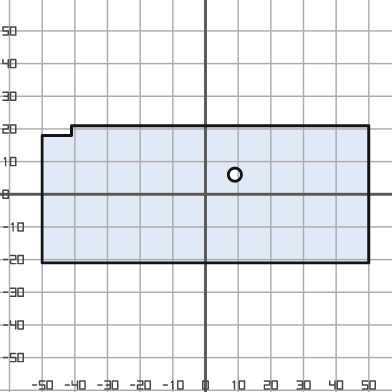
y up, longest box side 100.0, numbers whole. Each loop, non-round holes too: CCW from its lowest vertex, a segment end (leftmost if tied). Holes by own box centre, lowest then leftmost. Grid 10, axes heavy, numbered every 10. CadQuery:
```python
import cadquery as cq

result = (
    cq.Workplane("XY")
    .moveTo(-50.0, -21.0)
    .lineTo(50.0, -21.0)
    .lineTo(50.0, 21.0)
    .lineTo(-41.0, 21.0)
    .lineTo(-41.0, 18.0)
    .lineTo(-50.0, 18.0)
    .close()
    .moveTo(9.0, 6.0)
    .circle(2.0)
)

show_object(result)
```